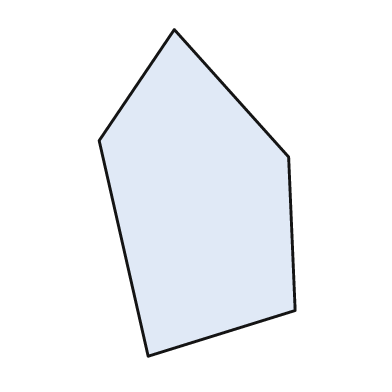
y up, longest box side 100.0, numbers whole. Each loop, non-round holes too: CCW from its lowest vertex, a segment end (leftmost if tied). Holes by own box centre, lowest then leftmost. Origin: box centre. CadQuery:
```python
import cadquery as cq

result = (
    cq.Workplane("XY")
    .moveTo(-15.0, -50.0)
    .lineTo(30.0, -36.0)
    .lineTo(28.0, 11.0)
    .lineTo(-7.0, 50.0)
    .lineTo(-30.0, 16.0)
    .close()
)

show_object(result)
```